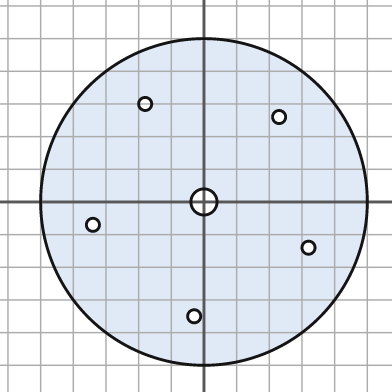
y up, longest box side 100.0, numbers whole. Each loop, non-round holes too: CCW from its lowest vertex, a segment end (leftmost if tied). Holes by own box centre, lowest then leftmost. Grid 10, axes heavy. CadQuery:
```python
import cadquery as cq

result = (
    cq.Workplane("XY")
    .moveTo(0.0, 0.0)
    .circle(50.0)
    .moveTo(-3.0, -35.0)
    .circle(2.0)
    .moveTo(32.0, -14.0)
    .circle(2.0)
    .moveTo(-34.0, -7.0)
    .circle(2.0)
    .moveTo(0.0, 0.0)
    .circle(4.0)
    .moveTo(23.0, 26.0)
    .circle(2.0)
    .moveTo(-18.0, 30.0)
    .circle(2.0)
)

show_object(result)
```